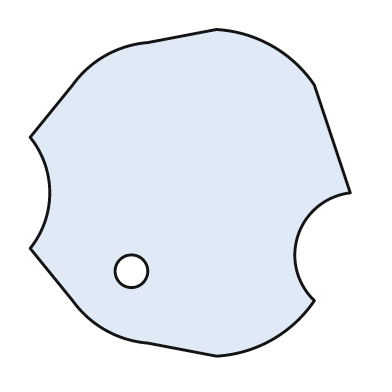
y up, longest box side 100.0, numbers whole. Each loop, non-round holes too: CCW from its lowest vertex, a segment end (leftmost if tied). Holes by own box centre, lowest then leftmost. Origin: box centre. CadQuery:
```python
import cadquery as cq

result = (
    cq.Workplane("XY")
    .moveTo(8.0, -50.0)
    .threePointArc((25.0, -45.0), (38.0, -33.0))
    .threePointArc((33.0, -13.0), (49.0, 0.0))
    .lineTo(38.0, 33.0)
    .threePointArc((25.0, 45.0), (8.0, 50.0))
    .lineTo(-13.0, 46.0)
    .threePointArc((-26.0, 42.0), (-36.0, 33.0))
    .lineTo(-49.0, 17.0)
    .threePointArc((-43.0, 0.0), (-49.0, -17.0))
    .lineTo(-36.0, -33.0)
    .threePointArc((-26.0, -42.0), (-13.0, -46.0))
    .close()
    .moveTo(-18.0, -24.0)
    .circle(5.0)
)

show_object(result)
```